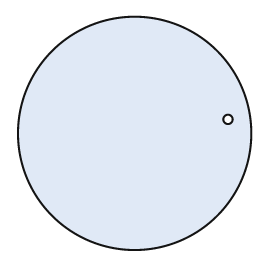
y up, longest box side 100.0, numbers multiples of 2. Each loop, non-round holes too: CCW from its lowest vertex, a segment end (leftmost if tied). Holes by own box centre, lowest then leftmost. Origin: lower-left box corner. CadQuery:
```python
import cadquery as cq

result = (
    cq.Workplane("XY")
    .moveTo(50.0, 50.0)
    .circle(50.0)
    .moveTo(90.0, 56.0)
    .circle(2.0)
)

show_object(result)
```